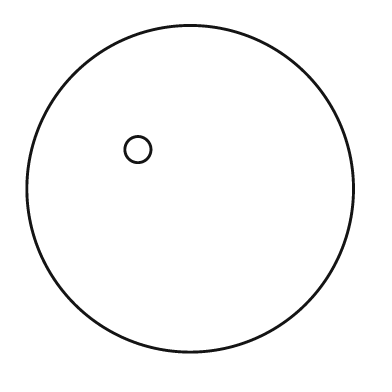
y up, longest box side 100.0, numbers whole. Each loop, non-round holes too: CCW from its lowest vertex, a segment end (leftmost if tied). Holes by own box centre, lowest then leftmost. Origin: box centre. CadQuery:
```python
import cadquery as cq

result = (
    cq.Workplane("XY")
    .moveTo(0.0, 0.0)
    .circle(50.0)
    .moveTo(-16.0, 12.0)
    .circle(4.0)
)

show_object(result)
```